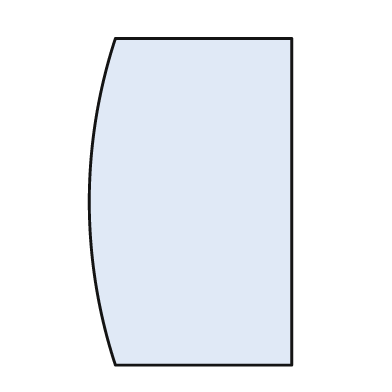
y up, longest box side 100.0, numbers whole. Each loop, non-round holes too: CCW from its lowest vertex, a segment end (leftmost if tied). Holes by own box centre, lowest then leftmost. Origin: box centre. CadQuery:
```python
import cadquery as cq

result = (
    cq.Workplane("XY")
    .moveTo(-23.0, -50.0)
    .lineTo(31.0, -50.0)
    .lineTo(31.0, 50.0)
    .lineTo(-23.0, 50.0)
    .threePointArc((-31.0, 0.0), (-23.0, -50.0))
    .close()
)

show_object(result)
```